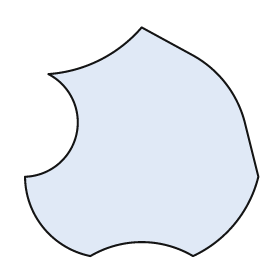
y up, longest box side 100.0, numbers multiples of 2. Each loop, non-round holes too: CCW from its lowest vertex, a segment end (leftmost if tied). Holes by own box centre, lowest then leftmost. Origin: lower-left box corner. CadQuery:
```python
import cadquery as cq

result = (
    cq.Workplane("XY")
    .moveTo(28.0, 0.0)
    .threePointArc((50.0, 6.0), (72.0, 0.0))
    .threePointArc((90.0, 14.0), (100.0, 34.0))
    .lineTo(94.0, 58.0)
    .threePointArc((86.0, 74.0), (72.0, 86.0))
    .lineTo(50.0, 98.0)
    .threePointArc((32.0, 84.0), (10.0, 78.0))
    .threePointArc((22.0, 52.0), (0.0, 34.0))
    .threePointArc((8.0, 12.0), (28.0, 0.0))
    .close()
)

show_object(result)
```